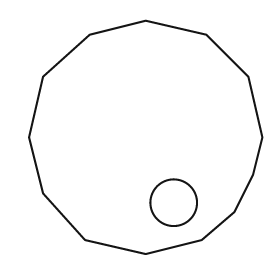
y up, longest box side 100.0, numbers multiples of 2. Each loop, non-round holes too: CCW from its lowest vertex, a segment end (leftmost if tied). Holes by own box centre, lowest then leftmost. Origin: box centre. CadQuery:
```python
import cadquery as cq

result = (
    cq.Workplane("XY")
    .moveTo(0.0, -50.0)
    .lineTo(24.0, -44.0)
    .lineTo(38.0, -32.0)
    .lineTo(46.0, -16.0)
    .lineTo(50.0, 0.0)
    .lineTo(44.0, 26.0)
    .lineTo(26.0, 44.0)
    .lineTo(0.0, 50.0)
    .lineTo(-24.0, 44.0)
    .lineTo(-44.0, 26.0)
    .lineTo(-50.0, 0.0)
    .lineTo(-44.0, -24.0)
    .lineTo(-26.0, -44.0)
    .close()
    .moveTo(12.0, -28.0)
    .circle(10.0)
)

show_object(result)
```